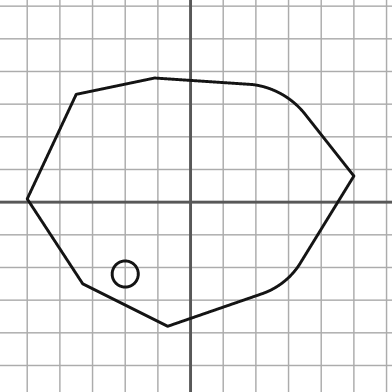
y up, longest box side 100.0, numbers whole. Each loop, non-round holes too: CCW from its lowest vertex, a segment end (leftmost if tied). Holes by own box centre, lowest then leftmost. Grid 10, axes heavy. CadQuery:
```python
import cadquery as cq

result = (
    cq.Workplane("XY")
    .moveTo(-7.0, -38.0)
    .lineTo(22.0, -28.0)
    .threePointArc((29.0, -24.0), (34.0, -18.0))
    .lineTo(50.0, 8.0)
    .lineTo(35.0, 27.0)
    .threePointArc((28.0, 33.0), (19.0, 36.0))
    .lineTo(-11.0, 38.0)
    .lineTo(-35.0, 33.0)
    .lineTo(-50.0, 1.0)
    .lineTo(-33.0, -25.0)
    .close()
    .moveTo(-20.0, -22.0)
    .circle(4.0)
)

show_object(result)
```